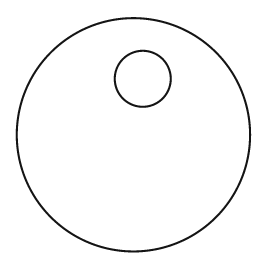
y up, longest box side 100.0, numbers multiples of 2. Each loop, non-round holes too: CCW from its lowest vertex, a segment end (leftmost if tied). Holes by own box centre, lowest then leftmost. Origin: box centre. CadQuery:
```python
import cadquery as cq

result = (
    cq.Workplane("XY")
    .moveTo(0.0, 0.0)
    .circle(50.0)
    .moveTo(4.0, 24.0)
    .circle(12.0)
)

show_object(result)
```